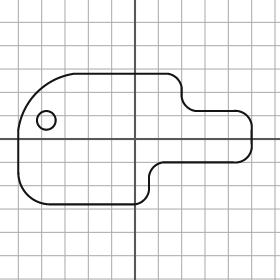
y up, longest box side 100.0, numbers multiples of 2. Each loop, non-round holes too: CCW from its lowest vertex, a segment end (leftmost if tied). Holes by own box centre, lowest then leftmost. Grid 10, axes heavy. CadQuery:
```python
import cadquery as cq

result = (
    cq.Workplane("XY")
    .moveTo(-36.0, -28.0)
    .lineTo(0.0, -28.0)
    .threePointArc((4.0, -26.0), (6.0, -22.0))
    .lineTo(6.0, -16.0)
    .threePointArc((8.0, -12.0), (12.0, -10.0))
    .lineTo(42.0, -10.0)
    .threePointArc((48.0, -8.0), (50.0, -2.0))
    .lineTo(50.0, 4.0)
    .threePointArc((48.0, 10.0), (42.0, 12.0))
    .lineTo(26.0, 12.0)
    .threePointArc((22.0, 14.0), (20.0, 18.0))
    .lineTo(20.0, 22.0)
    .threePointArc((18.0, 26.0), (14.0, 28.0))
    .lineTo(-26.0, 28.0)
    .threePointArc((-42.0, 20.0), (-50.0, 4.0))
    .lineTo(-50.0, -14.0)
    .threePointArc((-46.0, -24.0), (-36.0, -28.0))
    .close()
    .moveTo(-38.0, 8.0)
    .circle(4.0)
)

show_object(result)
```